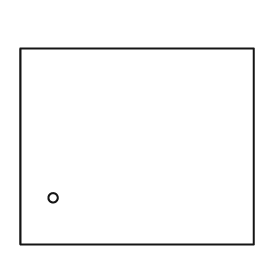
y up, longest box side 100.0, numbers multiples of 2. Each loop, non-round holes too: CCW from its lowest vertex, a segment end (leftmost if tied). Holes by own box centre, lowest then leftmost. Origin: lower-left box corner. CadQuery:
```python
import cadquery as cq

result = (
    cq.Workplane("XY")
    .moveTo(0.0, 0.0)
    .lineTo(100.0, 0.0)
    .lineTo(100.0, 84.0)
    .lineTo(0.0, 84.0)
    .close()
    .moveTo(14.0, 20.0)
    .circle(2.0)
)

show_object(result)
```